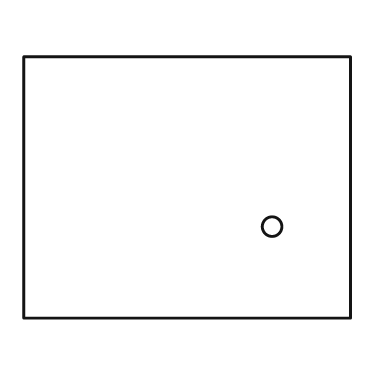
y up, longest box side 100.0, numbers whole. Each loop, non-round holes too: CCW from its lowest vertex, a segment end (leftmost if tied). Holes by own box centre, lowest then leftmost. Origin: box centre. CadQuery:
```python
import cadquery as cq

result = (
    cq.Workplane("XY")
    .moveTo(-50.0, -40.0)
    .lineTo(50.0, -40.0)
    .lineTo(50.0, 40.0)
    .lineTo(-50.0, 40.0)
    .close()
    .moveTo(26.0, -12.0)
    .circle(3.0)
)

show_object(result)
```